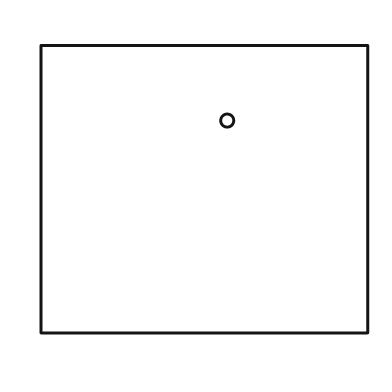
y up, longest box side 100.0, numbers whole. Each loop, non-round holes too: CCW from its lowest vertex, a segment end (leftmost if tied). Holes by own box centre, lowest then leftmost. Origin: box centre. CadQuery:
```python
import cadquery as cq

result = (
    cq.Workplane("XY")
    .moveTo(-50.0, -44.0)
    .lineTo(50.0, -44.0)
    .lineTo(50.0, 44.0)
    .lineTo(-50.0, 44.0)
    .close()
    .moveTo(7.0, 21.0)
    .circle(2.0)
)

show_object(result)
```